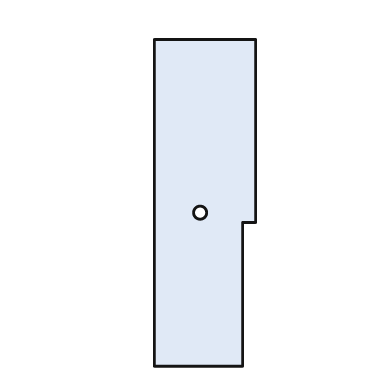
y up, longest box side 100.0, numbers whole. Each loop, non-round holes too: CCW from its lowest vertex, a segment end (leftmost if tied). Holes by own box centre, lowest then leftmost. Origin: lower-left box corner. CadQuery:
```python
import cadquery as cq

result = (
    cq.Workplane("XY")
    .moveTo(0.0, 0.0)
    .lineTo(27.0, 0.0)
    .lineTo(27.0, 44.0)
    .lineTo(31.0, 44.0)
    .lineTo(31.0, 100.0)
    .lineTo(0.0, 100.0)
    .close()
    .moveTo(14.0, 47.0)
    .circle(2.0)
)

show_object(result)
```